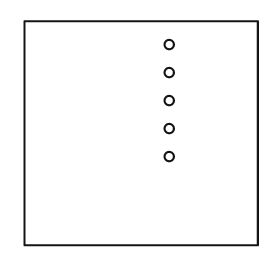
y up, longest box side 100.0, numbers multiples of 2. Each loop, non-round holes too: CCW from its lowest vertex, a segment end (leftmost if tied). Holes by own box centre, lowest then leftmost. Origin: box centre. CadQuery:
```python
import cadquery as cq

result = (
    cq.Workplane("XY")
    .moveTo(-50.0, -48.0)
    .lineTo(50.0, -48.0)
    .lineTo(50.0, 48.0)
    .lineTo(-50.0, 48.0)
    .close()
    .moveTo(12.0, -10.0)
    .circle(2.0)
    .moveTo(12.0, 2.0)
    .circle(2.0)
    .moveTo(12.0, 14.0)
    .circle(2.0)
    .moveTo(12.0, 26.0)
    .circle(2.0)
    .moveTo(12.0, 38.0)
    .circle(2.0)
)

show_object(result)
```